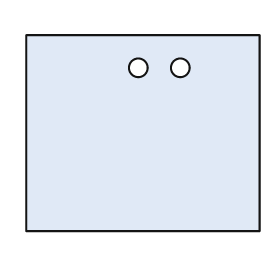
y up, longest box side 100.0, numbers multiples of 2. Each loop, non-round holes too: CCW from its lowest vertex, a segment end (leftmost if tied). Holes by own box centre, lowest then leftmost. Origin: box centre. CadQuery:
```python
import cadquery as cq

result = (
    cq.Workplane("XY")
    .moveTo(-50.0, -42.0)
    .lineTo(50.0, -42.0)
    .lineTo(50.0, 42.0)
    .lineTo(-50.0, 42.0)
    .close()
    .moveTo(-2.0, 28.0)
    .circle(4.0)
    .moveTo(16.0, 28.0)
    .circle(4.0)
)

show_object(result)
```